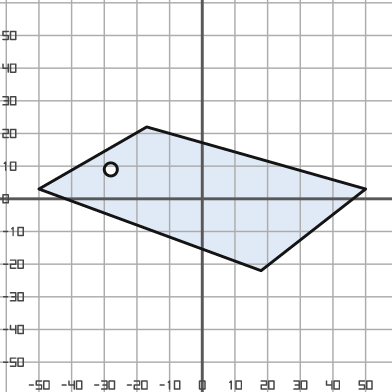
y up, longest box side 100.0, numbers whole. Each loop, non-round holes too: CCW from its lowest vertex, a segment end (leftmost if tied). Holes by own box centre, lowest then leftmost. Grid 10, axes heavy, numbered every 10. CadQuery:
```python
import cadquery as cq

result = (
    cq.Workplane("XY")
    .moveTo(18.0, -22.0)
    .lineTo(50.0, 3.0)
    .lineTo(-17.0, 22.0)
    .lineTo(-50.0, 3.0)
    .close()
    .moveTo(-28.0, 9.0)
    .circle(2.0)
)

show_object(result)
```